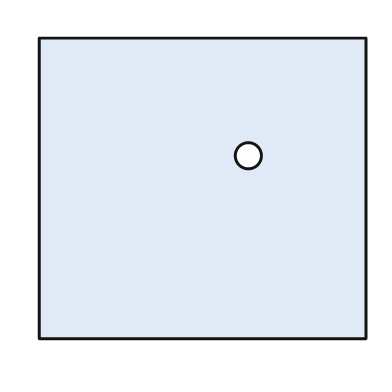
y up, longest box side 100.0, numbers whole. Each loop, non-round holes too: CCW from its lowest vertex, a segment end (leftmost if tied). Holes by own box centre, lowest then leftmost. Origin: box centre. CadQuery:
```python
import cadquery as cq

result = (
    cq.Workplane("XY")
    .moveTo(-50.0, -46.0)
    .lineTo(50.0, -46.0)
    .lineTo(50.0, 46.0)
    .lineTo(-50.0, 46.0)
    .close()
    .moveTo(14.0, 10.0)
    .circle(4.0)
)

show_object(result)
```